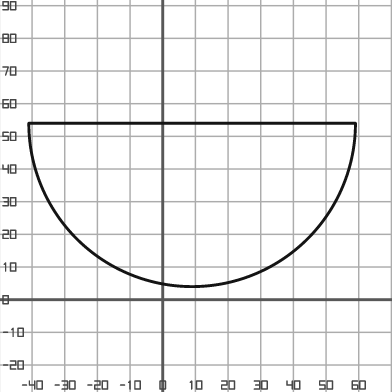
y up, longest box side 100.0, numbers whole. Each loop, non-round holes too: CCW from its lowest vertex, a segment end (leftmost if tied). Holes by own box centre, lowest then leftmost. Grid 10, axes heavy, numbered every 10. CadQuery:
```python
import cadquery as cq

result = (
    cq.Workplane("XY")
    .moveTo(-41.0, 54.0)
    .threePointArc((9.0, 4.0), (59.0, 54.0))
    .close()
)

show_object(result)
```